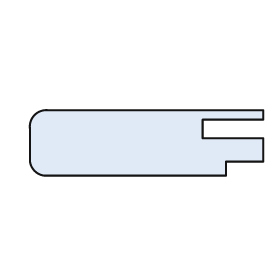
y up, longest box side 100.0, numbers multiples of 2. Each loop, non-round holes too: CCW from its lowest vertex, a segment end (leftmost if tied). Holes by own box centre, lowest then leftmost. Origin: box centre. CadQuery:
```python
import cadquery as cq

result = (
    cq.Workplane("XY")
    .moveTo(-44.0, -14.0)
    .lineTo(34.0, -14.0)
    .lineTo(34.0, -8.0)
    .lineTo(50.0, -8.0)
    .lineTo(50.0, 2.0)
    .lineTo(24.0, 2.0)
    .lineTo(24.0, 10.0)
    .lineTo(50.0, 10.0)
    .lineTo(50.0, 14.0)
    .lineTo(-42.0, 14.0)
    .threePointArc((-48.0, 12.0), (-50.0, 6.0))
    .lineTo(-50.0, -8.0)
    .threePointArc((-48.0, -12.0), (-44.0, -14.0))
    .close()
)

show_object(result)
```